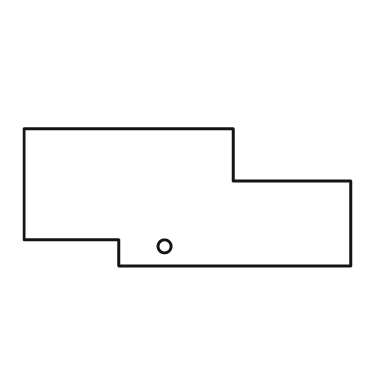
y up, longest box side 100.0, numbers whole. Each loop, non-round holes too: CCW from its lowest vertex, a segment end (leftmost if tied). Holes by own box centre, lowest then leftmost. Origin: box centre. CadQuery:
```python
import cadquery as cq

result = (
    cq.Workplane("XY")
    .moveTo(-21.0, -21.0)
    .lineTo(50.0, -21.0)
    .lineTo(50.0, 5.0)
    .lineTo(14.0, 5.0)
    .lineTo(14.0, 21.0)
    .lineTo(-50.0, 21.0)
    .lineTo(-50.0, -13.0)
    .lineTo(-21.0, -13.0)
    .close()
    .moveTo(-7.0, -15.0)
    .circle(2.0)
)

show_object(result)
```